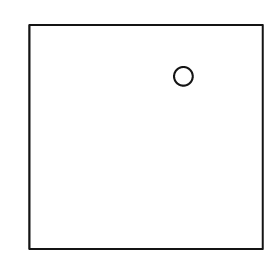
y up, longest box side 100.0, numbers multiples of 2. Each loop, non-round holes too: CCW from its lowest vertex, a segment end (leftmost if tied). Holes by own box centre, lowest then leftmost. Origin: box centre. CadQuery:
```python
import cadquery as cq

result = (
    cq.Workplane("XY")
    .moveTo(-50.0, -48.0)
    .lineTo(50.0, -48.0)
    .lineTo(50.0, 48.0)
    .lineTo(-50.0, 48.0)
    .close()
    .moveTo(16.0, 26.0)
    .circle(4.0)
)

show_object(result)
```